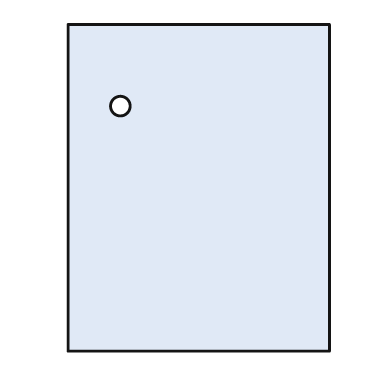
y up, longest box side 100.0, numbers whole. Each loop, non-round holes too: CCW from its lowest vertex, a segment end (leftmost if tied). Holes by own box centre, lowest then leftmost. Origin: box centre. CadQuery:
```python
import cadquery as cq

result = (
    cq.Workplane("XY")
    .moveTo(-40.0, -50.0)
    .lineTo(40.0, -50.0)
    .lineTo(40.0, 50.0)
    .lineTo(-40.0, 50.0)
    .close()
    .moveTo(-24.0, 25.0)
    .circle(3.0)
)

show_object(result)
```